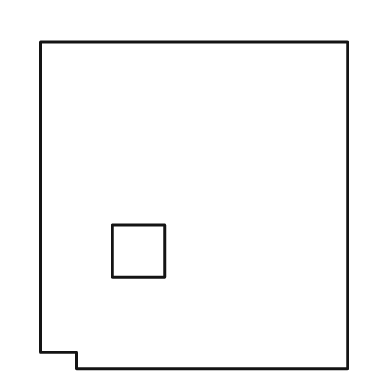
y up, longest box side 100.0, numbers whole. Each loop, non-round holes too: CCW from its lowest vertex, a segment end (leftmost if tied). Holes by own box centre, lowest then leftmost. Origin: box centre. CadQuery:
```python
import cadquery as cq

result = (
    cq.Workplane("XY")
    .moveTo(-36.0, -50.0)
    .lineTo(47.0, -50.0)
    .lineTo(47.0, 50.0)
    .lineTo(-47.0, 50.0)
    .lineTo(-47.0, -45.0)
    .lineTo(-36.0, -45.0)
    .close()
    .moveTo(-25.0, -22.0)
    .lineTo(-9.0, -22.0)
    .lineTo(-9.0, -6.0)
    .lineTo(-25.0, -6.0)
    .close()
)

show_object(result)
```